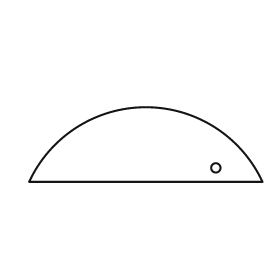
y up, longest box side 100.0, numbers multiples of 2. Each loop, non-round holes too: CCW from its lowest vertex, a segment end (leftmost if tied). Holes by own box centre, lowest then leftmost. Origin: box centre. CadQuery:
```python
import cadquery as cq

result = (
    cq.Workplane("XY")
    .moveTo(-50.0, -16.0)
    .lineTo(50.0, -16.0)
    .threePointArc((0.0, 16.0), (-50.0, -16.0))
    .close()
    .moveTo(30.0, -10.0)
    .circle(2.0)
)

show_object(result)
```